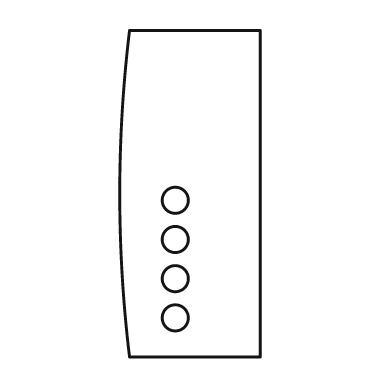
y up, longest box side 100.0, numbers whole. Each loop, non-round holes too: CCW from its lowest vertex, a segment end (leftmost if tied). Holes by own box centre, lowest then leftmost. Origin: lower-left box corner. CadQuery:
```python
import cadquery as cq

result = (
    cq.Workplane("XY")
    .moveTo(3.0, 0.0)
    .lineTo(43.0, 0.0)
    .lineTo(43.0, 100.0)
    .lineTo(3.0, 100.0)
    .threePointArc((0.0, 50.0), (3.0, 0.0))
    .close()
    .moveTo(17.0, 12.0)
    .circle(4.0)
    .moveTo(17.0, 24.0)
    .circle(4.0)
    .moveTo(17.0, 36.0)
    .circle(4.0)
    .moveTo(17.0, 48.0)
    .circle(4.0)
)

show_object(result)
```